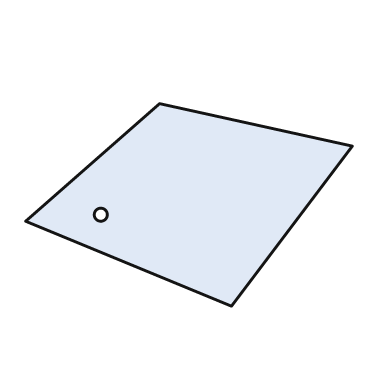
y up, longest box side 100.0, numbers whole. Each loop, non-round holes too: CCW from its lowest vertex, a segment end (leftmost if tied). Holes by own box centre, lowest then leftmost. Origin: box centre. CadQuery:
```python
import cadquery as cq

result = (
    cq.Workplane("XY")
    .moveTo(13.0, -31.0)
    .lineTo(50.0, 18.0)
    .lineTo(-9.0, 31.0)
    .lineTo(-50.0, -5.0)
    .close()
    .moveTo(-27.0, -3.0)
    .circle(2.0)
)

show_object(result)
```